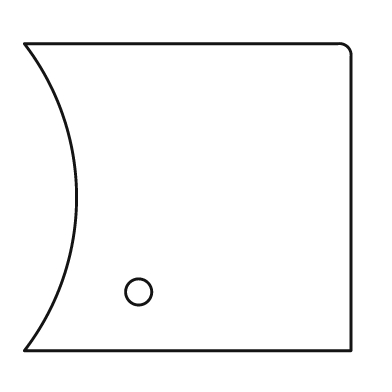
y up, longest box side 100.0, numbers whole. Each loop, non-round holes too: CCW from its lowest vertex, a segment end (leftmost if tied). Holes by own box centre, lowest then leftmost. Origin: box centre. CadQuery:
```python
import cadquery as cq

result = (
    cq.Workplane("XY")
    .moveTo(-50.0, -47.0)
    .lineTo(50.0, -47.0)
    .lineTo(50.0, 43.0)
    .threePointArc((49.0, 46.0), (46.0, 47.0))
    .lineTo(-50.0, 47.0)
    .threePointArc((-34.0, 0.0), (-50.0, -47.0))
    .close()
    .moveTo(-15.0, -29.0)
    .circle(4.0)
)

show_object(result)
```